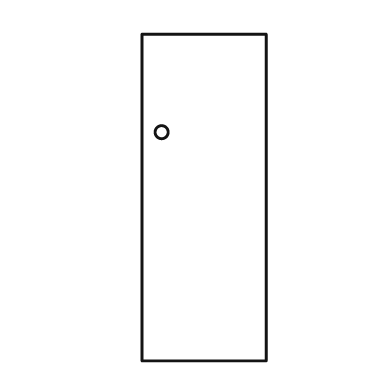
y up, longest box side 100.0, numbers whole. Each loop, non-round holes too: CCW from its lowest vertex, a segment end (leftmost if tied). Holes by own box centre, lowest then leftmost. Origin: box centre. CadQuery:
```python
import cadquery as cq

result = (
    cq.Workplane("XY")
    .moveTo(-19.0, -50.0)
    .lineTo(19.0, -50.0)
    .lineTo(19.0, 50.0)
    .lineTo(-19.0, 50.0)
    .close()
    .moveTo(-13.0, 20.0)
    .circle(2.0)
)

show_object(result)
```